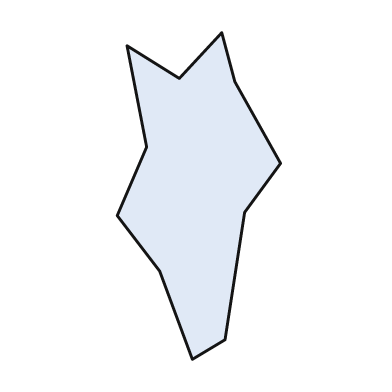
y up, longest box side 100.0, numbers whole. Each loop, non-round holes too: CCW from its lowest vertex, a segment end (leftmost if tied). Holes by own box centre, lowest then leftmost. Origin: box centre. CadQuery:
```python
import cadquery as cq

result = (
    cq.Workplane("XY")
    .moveTo(-2.0, -50.0)
    .lineTo(8.0, -44.0)
    .lineTo(14.0, -5.0)
    .lineTo(25.0, 10.0)
    .lineTo(11.0, 35.0)
    .lineTo(7.0, 50.0)
    .lineTo(-6.0, 36.0)
    .lineTo(-22.0, 46.0)
    .lineTo(-16.0, 15.0)
    .lineTo(-25.0, -6.0)
    .lineTo(-12.0, -23.0)
    .close()
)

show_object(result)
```